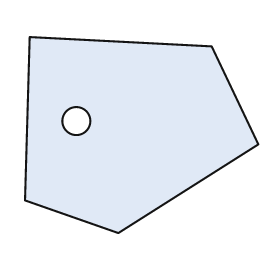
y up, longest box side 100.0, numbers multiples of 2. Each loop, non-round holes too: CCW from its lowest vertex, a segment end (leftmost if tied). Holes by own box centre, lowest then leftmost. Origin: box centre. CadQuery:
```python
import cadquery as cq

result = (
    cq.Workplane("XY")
    .moveTo(-10.0, -42.0)
    .lineTo(50.0, -4.0)
    .lineTo(30.0, 38.0)
    .lineTo(-48.0, 42.0)
    .lineTo(-50.0, -28.0)
    .close()
    .moveTo(-28.0, 6.0)
    .circle(6.0)
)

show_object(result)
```